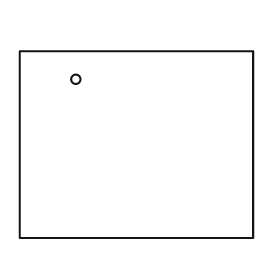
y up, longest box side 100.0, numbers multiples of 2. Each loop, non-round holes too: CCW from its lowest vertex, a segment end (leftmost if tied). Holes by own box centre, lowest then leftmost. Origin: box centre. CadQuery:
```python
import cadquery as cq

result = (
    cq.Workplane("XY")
    .moveTo(-50.0, -40.0)
    .lineTo(50.0, -40.0)
    .lineTo(50.0, 40.0)
    .lineTo(-50.0, 40.0)
    .close()
    .moveTo(-26.0, 28.0)
    .circle(2.0)
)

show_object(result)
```